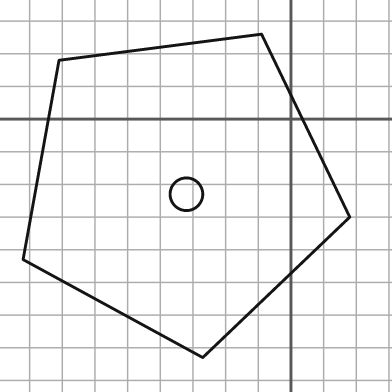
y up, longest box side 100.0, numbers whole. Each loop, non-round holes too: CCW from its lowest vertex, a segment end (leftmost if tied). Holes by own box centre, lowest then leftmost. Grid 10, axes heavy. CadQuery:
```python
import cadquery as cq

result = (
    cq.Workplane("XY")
    .moveTo(-27.0, -73.0)
    .lineTo(18.0, -30.0)
    .lineTo(-9.0, 26.0)
    .lineTo(-71.0, 18.0)
    .lineTo(-82.0, -43.0)
    .close()
    .moveTo(-32.0, -23.0)
    .circle(5.0)
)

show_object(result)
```